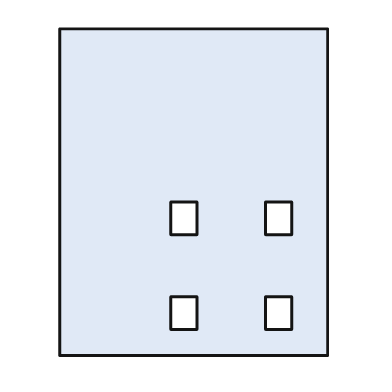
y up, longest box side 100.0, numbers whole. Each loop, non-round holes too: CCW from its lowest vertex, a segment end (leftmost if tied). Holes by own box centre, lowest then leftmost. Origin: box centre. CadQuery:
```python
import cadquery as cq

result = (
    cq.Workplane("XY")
    .moveTo(-41.0, -50.0)
    .lineTo(41.0, -50.0)
    .lineTo(41.0, 50.0)
    .lineTo(-41.0, 50.0)
    .close()
    .moveTo(-7.0, -42.0)
    .lineTo(1.0, -42.0)
    .lineTo(1.0, -32.0)
    .lineTo(-7.0, -32.0)
    .close()
    .moveTo(22.0, -42.0)
    .lineTo(30.0, -42.0)
    .lineTo(30.0, -32.0)
    .lineTo(22.0, -32.0)
    .close()
    .moveTo(-7.0, -13.0)
    .lineTo(1.0, -13.0)
    .lineTo(1.0, -3.0)
    .lineTo(-7.0, -3.0)
    .close()
    .moveTo(22.0, -13.0)
    .lineTo(30.0, -13.0)
    .lineTo(30.0, -3.0)
    .lineTo(22.0, -3.0)
    .close()
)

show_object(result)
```